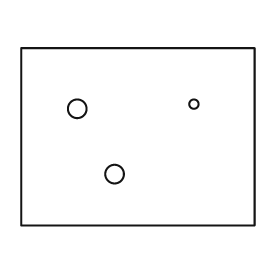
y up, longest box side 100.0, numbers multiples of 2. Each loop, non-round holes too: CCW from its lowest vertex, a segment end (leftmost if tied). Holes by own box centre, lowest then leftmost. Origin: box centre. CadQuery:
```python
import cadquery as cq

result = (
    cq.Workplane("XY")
    .moveTo(-50.0, -38.0)
    .lineTo(50.0, -38.0)
    .lineTo(50.0, 38.0)
    .lineTo(-50.0, 38.0)
    .close()
    .moveTo(-10.0, -16.0)
    .circle(4.0)
    .moveTo(-26.0, 12.0)
    .circle(4.0)
    .moveTo(24.0, 14.0)
    .circle(2.0)
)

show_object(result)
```